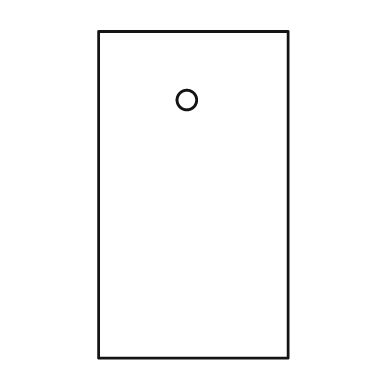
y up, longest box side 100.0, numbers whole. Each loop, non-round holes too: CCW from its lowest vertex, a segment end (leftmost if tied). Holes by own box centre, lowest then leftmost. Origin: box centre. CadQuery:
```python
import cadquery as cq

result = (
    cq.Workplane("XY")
    .moveTo(-29.0, -50.0)
    .lineTo(29.0, -50.0)
    .lineTo(29.0, 50.0)
    .lineTo(-29.0, 50.0)
    .close()
    .moveTo(-2.0, 29.0)
    .circle(3.0)
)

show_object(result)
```